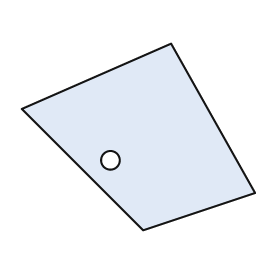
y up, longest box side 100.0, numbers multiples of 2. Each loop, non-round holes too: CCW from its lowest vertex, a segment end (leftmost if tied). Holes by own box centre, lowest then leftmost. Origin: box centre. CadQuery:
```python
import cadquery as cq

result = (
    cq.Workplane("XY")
    .moveTo(2.0, -40.0)
    .lineTo(50.0, -24.0)
    .lineTo(14.0, 40.0)
    .lineTo(-50.0, 12.0)
    .close()
    .moveTo(-12.0, -10.0)
    .circle(4.0)
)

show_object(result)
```